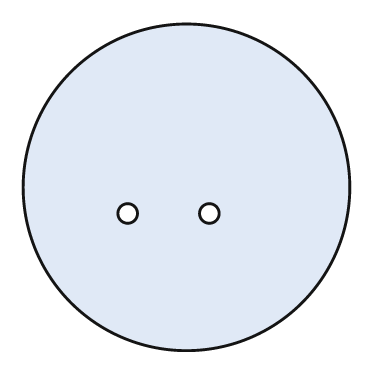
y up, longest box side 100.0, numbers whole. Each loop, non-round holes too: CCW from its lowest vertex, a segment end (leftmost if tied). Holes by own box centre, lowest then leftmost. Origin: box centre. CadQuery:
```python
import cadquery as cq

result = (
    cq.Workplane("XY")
    .moveTo(0.0, 0.0)
    .circle(50.0)
    .moveTo(-18.0, -8.0)
    .circle(3.0)
    .moveTo(7.0, -8.0)
    .circle(3.0)
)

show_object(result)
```